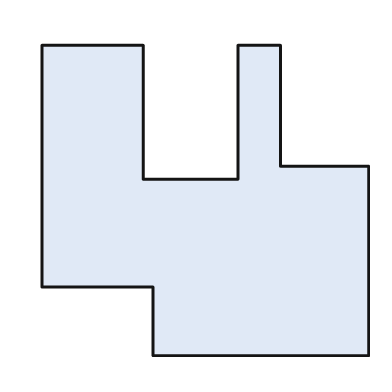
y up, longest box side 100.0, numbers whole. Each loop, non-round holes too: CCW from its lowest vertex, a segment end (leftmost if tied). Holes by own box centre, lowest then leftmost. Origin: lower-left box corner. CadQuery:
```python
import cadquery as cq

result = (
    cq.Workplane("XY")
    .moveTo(34.0, 0.0)
    .lineTo(100.0, 0.0)
    .lineTo(100.0, 58.0)
    .lineTo(73.0, 58.0)
    .lineTo(73.0, 95.0)
    .lineTo(60.0, 95.0)
    .lineTo(60.0, 54.0)
    .lineTo(31.0, 54.0)
    .lineTo(31.0, 95.0)
    .lineTo(0.0, 95.0)
    .lineTo(0.0, 21.0)
    .lineTo(34.0, 21.0)
    .close()
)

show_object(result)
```